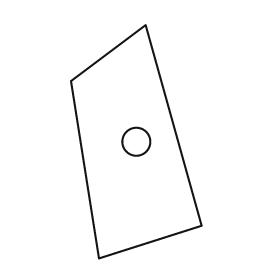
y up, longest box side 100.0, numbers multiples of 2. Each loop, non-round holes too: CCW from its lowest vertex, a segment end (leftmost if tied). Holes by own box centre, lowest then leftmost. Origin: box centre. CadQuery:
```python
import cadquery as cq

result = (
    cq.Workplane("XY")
    .moveTo(-16.0, -50.0)
    .lineTo(28.0, -36.0)
    .lineTo(4.0, 50.0)
    .lineTo(-28.0, 26.0)
    .close()
    .moveTo(0.0, 0.0)
    .circle(6.0)
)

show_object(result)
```